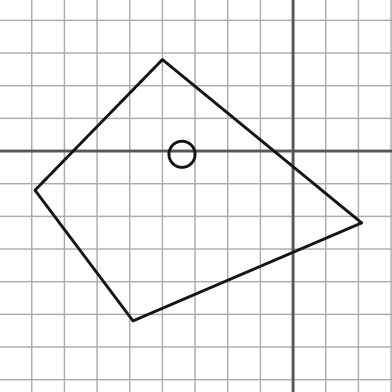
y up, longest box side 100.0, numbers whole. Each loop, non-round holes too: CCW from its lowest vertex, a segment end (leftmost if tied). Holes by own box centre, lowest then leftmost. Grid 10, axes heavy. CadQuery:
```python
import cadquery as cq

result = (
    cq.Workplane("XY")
    .moveTo(-49.0, -52.0)
    .lineTo(21.0, -22.0)
    .lineTo(-40.0, 28.0)
    .lineTo(-79.0, -12.0)
    .close()
    .moveTo(-34.0, -1.0)
    .circle(4.0)
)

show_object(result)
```